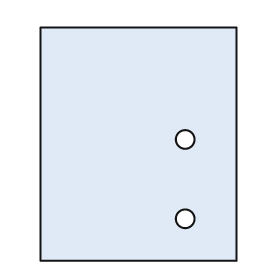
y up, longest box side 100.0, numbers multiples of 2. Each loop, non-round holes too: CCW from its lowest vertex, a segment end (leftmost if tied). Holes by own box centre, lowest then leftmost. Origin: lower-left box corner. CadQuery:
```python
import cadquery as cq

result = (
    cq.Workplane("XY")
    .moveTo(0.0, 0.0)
    .lineTo(84.0, 0.0)
    .lineTo(84.0, 100.0)
    .lineTo(0.0, 100.0)
    .close()
    .moveTo(62.0, 18.0)
    .circle(4.0)
    .moveTo(62.0, 52.0)
    .circle(4.0)
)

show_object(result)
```